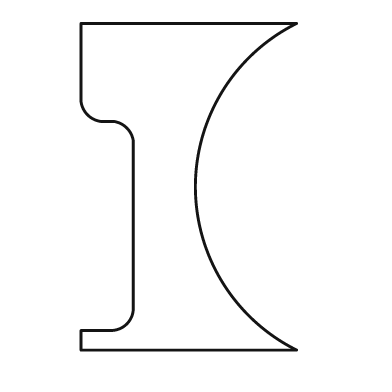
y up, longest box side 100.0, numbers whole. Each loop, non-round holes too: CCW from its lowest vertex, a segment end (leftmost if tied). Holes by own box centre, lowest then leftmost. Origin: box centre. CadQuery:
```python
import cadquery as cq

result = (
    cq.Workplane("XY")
    .moveTo(-33.0, -50.0)
    .lineTo(33.0, -50.0)
    .threePointArc((2.0, 0.0), (33.0, 50.0))
    .lineTo(-33.0, 50.0)
    .lineTo(-33.0, 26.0)
    .threePointArc((-31.0, 22.0), (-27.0, 20.0))
    .lineTo(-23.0, 20.0)
    .threePointArc((-19.0, 18.0), (-17.0, 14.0))
    .lineTo(-17.0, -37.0)
    .threePointArc((-19.0, -42.0), (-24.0, -44.0))
    .lineTo(-33.0, -44.0)
    .close()
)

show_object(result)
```